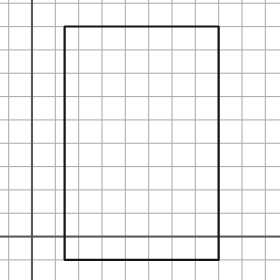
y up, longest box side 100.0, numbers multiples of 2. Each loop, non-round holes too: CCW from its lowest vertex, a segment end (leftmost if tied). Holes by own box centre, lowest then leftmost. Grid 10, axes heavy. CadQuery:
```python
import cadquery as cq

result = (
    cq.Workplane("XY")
    .moveTo(14.0, -10.0)
    .lineTo(80.0, -10.0)
    .lineTo(80.0, 90.0)
    .lineTo(14.0, 90.0)
    .close()
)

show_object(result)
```